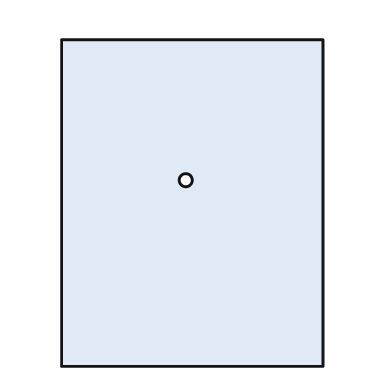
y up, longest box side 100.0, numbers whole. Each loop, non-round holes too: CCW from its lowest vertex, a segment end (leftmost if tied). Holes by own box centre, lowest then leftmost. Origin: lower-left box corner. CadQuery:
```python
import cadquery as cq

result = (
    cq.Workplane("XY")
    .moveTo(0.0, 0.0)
    .lineTo(80.0, 0.0)
    .lineTo(80.0, 100.0)
    .lineTo(0.0, 100.0)
    .close()
    .moveTo(38.0, 57.0)
    .circle(2.0)
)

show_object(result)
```